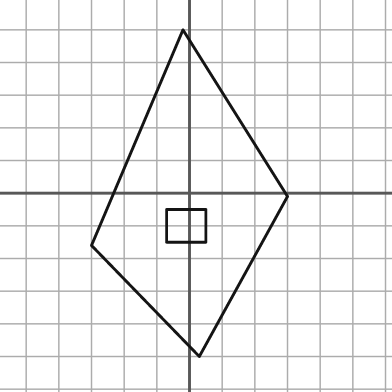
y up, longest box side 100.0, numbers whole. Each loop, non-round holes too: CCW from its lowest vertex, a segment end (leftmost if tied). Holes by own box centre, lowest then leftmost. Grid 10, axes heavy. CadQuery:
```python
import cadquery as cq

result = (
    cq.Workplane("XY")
    .moveTo(3.0, -50.0)
    .lineTo(30.0, -1.0)
    .lineTo(-2.0, 50.0)
    .lineTo(-30.0, -16.0)
    .close()
    .moveTo(-7.0, -15.0)
    .lineTo(5.0, -15.0)
    .lineTo(5.0, -5.0)
    .lineTo(-7.0, -5.0)
    .close()
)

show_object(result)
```